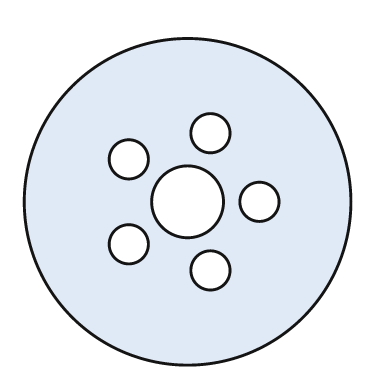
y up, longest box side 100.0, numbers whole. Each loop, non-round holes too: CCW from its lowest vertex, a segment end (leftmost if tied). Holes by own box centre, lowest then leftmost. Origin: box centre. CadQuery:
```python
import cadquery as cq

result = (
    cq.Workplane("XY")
    .moveTo(0.0, 0.0)
    .circle(50.0)
    .moveTo(7.0, -21.0)
    .circle(6.0)
    .moveTo(-18.0, -13.0)
    .circle(6.0)
    .moveTo(0.0, 0.0)
    .circle(11.0)
    .moveTo(22.0, 0.0)
    .circle(6.0)
    .moveTo(-18.0, 13.0)
    .circle(6.0)
    .moveTo(7.0, 21.0)
    .circle(6.0)
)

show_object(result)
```